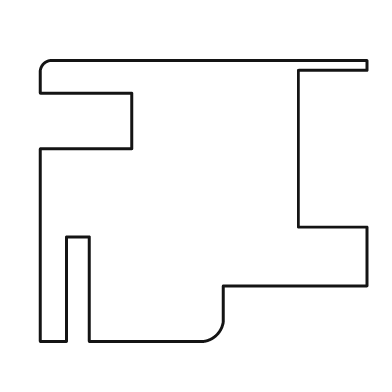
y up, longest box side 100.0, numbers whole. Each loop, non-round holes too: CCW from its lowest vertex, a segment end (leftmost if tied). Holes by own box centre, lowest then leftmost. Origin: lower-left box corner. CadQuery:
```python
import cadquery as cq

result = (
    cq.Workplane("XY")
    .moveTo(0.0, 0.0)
    .lineTo(8.0, 0.0)
    .lineTo(8.0, 32.0)
    .lineTo(15.0, 32.0)
    .lineTo(15.0, 0.0)
    .lineTo(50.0, 0.0)
    .threePointArc((54.0, 2.0), (56.0, 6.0))
    .lineTo(56.0, 17.0)
    .lineTo(100.0, 17.0)
    .lineTo(100.0, 35.0)
    .lineTo(79.0, 35.0)
    .lineTo(79.0, 83.0)
    .lineTo(100.0, 83.0)
    .lineTo(100.0, 86.0)
    .lineTo(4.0, 86.0)
    .threePointArc((1.0, 85.0), (0.0, 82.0))
    .lineTo(0.0, 76.0)
    .lineTo(28.0, 76.0)
    .lineTo(28.0, 59.0)
    .lineTo(0.0, 59.0)
    .close()
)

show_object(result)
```